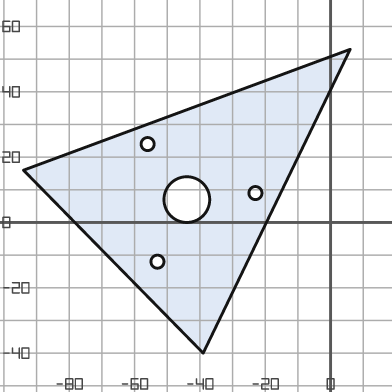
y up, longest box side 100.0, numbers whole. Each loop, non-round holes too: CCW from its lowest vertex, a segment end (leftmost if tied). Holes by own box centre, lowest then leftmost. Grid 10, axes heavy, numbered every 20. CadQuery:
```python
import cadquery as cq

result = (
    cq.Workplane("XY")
    .moveTo(-39.0, -40.0)
    .lineTo(6.0, 53.0)
    .lineTo(-94.0, 16.0)
    .close()
    .moveTo(-53.0, -12.0)
    .circle(2.0)
    .moveTo(-44.0, 7.0)
    .circle(7.0)
    .moveTo(-23.0, 9.0)
    .circle(2.0)
    .moveTo(-56.0, 24.0)
    .circle(2.0)
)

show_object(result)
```